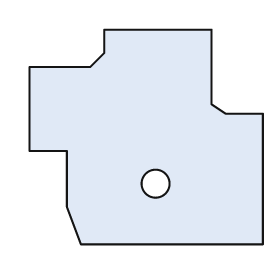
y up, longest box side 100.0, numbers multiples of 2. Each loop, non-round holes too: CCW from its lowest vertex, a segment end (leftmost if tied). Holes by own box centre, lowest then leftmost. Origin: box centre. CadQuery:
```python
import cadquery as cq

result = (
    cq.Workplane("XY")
    .moveTo(-28.0, -46.0)
    .lineTo(50.0, -46.0)
    .lineTo(50.0, 10.0)
    .lineTo(34.0, 10.0)
    .lineTo(28.0, 14.0)
    .lineTo(28.0, 46.0)
    .lineTo(-18.0, 46.0)
    .lineTo(-18.0, 36.0)
    .lineTo(-24.0, 30.0)
    .lineTo(-50.0, 30.0)
    .lineTo(-50.0, -6.0)
    .lineTo(-34.0, -6.0)
    .lineTo(-34.0, -30.0)
    .close()
    .moveTo(4.0, -20.0)
    .circle(6.0)
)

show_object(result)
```